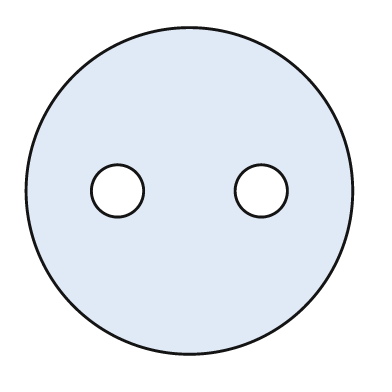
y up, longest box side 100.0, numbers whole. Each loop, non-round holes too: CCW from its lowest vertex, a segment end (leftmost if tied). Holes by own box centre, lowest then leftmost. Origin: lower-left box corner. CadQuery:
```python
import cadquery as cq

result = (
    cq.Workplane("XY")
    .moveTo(50.0, 50.0)
    .circle(50.0)
    .moveTo(28.0, 50.0)
    .circle(8.0)
    .moveTo(72.0, 50.0)
    .circle(8.0)
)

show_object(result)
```